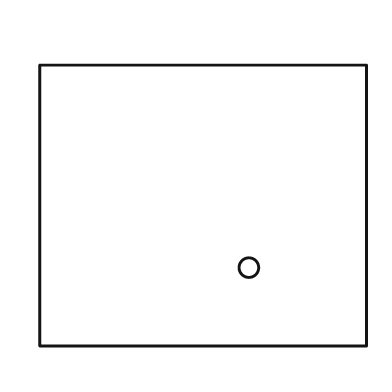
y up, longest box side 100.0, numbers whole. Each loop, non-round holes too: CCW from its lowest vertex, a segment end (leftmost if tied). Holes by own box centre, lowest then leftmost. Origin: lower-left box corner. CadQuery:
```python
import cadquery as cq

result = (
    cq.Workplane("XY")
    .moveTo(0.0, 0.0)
    .lineTo(100.0, 0.0)
    .lineTo(100.0, 86.0)
    .lineTo(0.0, 86.0)
    .close()
    .moveTo(64.0, 24.0)
    .circle(3.0)
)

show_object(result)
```